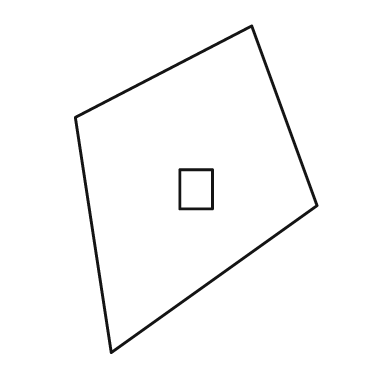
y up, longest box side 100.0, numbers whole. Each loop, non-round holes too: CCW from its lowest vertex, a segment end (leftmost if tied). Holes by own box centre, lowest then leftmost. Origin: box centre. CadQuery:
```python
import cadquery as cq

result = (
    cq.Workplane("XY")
    .moveTo(-26.0, -50.0)
    .lineTo(37.0, -5.0)
    .lineTo(17.0, 50.0)
    .lineTo(-37.0, 22.0)
    .close()
    .moveTo(-5.0, -6.0)
    .lineTo(5.0, -6.0)
    .lineTo(5.0, 6.0)
    .lineTo(-5.0, 6.0)
    .close()
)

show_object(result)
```